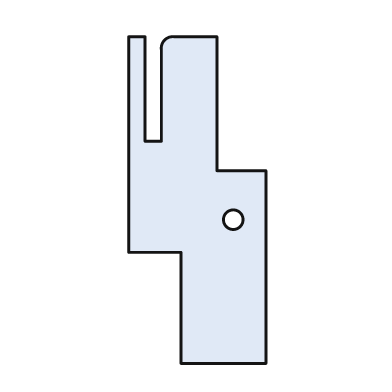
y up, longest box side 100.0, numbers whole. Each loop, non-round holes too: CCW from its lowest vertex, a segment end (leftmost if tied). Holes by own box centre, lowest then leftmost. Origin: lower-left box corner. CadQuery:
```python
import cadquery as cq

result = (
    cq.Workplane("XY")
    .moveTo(16.0, 0.0)
    .lineTo(42.0, 0.0)
    .lineTo(42.0, 59.0)
    .lineTo(27.0, 59.0)
    .lineTo(27.0, 100.0)
    .lineTo(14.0, 100.0)
    .threePointArc((11.0, 99.0), (10.0, 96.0))
    .lineTo(10.0, 68.0)
    .lineTo(5.0, 68.0)
    .lineTo(5.0, 100.0)
    .lineTo(0.0, 100.0)
    .lineTo(0.0, 34.0)
    .lineTo(16.0, 34.0)
    .close()
    .moveTo(32.0, 44.0)
    .circle(3.0)
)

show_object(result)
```